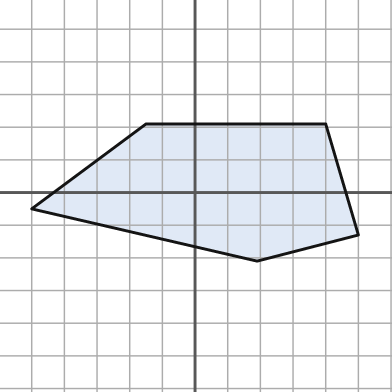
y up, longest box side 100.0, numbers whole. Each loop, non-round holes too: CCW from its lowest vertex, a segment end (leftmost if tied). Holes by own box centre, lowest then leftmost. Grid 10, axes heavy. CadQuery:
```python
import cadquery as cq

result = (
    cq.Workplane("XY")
    .moveTo(19.0, -21.0)
    .lineTo(50.0, -13.0)
    .lineTo(40.0, 21.0)
    .lineTo(-15.0, 21.0)
    .lineTo(-50.0, -5.0)
    .close()
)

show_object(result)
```